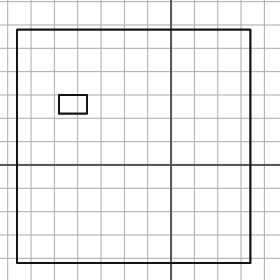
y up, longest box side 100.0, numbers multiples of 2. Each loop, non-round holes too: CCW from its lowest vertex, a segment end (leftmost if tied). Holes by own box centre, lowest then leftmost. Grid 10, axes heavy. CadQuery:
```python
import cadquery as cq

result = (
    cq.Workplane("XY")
    .moveTo(-66.0, -42.0)
    .lineTo(34.0, -42.0)
    .lineTo(34.0, 58.0)
    .lineTo(-66.0, 58.0)
    .close()
    .moveTo(-48.0, 22.0)
    .lineTo(-36.0, 22.0)
    .lineTo(-36.0, 30.0)
    .lineTo(-48.0, 30.0)
    .close()
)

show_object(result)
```